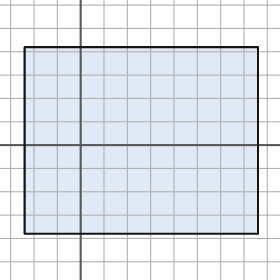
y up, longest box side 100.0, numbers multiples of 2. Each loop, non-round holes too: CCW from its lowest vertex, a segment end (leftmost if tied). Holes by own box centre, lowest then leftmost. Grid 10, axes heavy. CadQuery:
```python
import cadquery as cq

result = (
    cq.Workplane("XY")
    .moveTo(-24.0, -38.0)
    .lineTo(76.0, -38.0)
    .lineTo(76.0, 42.0)
    .lineTo(-24.0, 42.0)
    .close()
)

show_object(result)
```